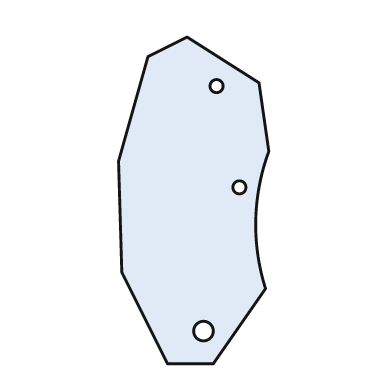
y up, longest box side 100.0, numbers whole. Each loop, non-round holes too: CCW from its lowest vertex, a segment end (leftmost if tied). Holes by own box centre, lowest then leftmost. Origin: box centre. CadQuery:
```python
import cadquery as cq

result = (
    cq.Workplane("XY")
    .moveTo(-8.0, -50.0)
    .lineTo(6.0, -50.0)
    .lineTo(22.0, -27.0)
    .threePointArc((19.0, -6.0), (23.0, 15.0))
    .lineTo(20.0, 36.0)
    .lineTo(-2.0, 50.0)
    .lineTo(-14.0, 44.0)
    .lineTo(-23.0, 12.0)
    .lineTo(-22.0, -22.0)
    .close()
    .moveTo(3.0, -40.0)
    .circle(3.0)
    .moveTo(14.0, 4.0)
    .circle(2.0)
    .moveTo(7.0, 35.0)
    .circle(2.0)
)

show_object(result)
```